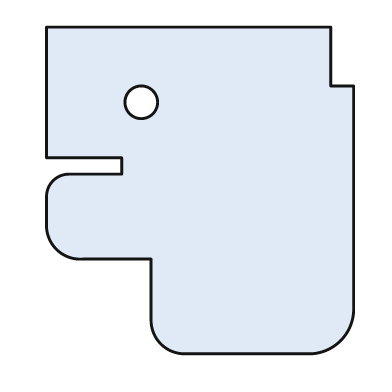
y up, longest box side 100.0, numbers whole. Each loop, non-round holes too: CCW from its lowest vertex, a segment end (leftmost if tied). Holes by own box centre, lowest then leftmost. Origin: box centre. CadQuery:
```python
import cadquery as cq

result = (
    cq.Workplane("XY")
    .moveTo(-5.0, -50.0)
    .lineTo(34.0, -50.0)
    .threePointArc((43.0, -46.0), (47.0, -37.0))
    .lineTo(47.0, 32.0)
    .lineTo(40.0, 32.0)
    .lineTo(40.0, 50.0)
    .lineTo(-47.0, 50.0)
    .lineTo(-47.0, 10.0)
    .lineTo(-24.0, 10.0)
    .lineTo(-24.0, 5.0)
    .lineTo(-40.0, 5.0)
    .threePointArc((-45.0, 3.0), (-47.0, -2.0))
    .lineTo(-47.0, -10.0)
    .threePointArc((-44.0, -18.0), (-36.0, -21.0))
    .lineTo(-15.0, -21.0)
    .lineTo(-15.0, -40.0)
    .threePointArc((-12.0, -47.0), (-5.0, -50.0))
    .close()
    .moveTo(-18.0, 27.0)
    .circle(5.0)
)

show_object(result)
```